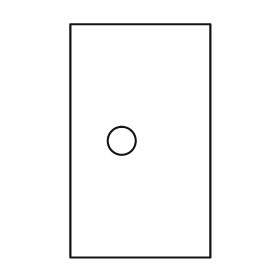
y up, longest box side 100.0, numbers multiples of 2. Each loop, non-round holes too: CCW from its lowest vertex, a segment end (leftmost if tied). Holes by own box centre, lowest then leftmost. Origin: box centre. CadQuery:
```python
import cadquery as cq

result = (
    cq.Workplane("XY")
    .moveTo(-30.0, -50.0)
    .lineTo(30.0, -50.0)
    .lineTo(30.0, 50.0)
    .lineTo(-30.0, 50.0)
    .close()
    .moveTo(-8.0, 0.0)
    .circle(6.0)
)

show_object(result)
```